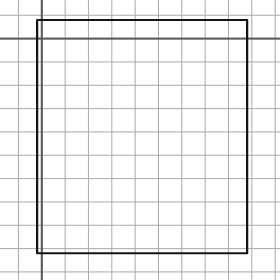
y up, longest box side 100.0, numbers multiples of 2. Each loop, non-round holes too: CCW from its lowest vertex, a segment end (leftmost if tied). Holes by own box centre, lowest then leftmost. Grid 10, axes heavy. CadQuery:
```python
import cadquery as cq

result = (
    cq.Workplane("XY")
    .moveTo(-2.0, -92.0)
    .lineTo(88.0, -92.0)
    .lineTo(88.0, 8.0)
    .lineTo(-2.0, 8.0)
    .close()
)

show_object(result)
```